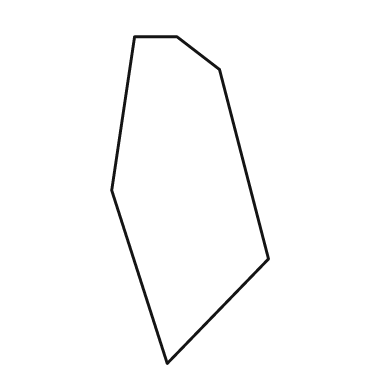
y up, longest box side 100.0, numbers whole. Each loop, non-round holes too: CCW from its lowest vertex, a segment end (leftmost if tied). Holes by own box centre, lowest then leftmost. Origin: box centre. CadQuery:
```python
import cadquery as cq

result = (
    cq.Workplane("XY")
    .moveTo(-7.0, -50.0)
    .lineTo(24.0, -18.0)
    .lineTo(9.0, 40.0)
    .lineTo(-4.0, 50.0)
    .lineTo(-17.0, 50.0)
    .lineTo(-24.0, 3.0)
    .close()
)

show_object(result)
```